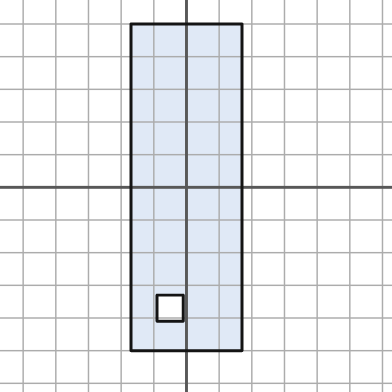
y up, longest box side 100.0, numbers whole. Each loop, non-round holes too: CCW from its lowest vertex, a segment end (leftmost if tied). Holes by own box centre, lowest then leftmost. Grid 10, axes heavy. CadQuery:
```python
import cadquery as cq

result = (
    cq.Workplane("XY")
    .moveTo(-17.0, -50.0)
    .lineTo(17.0, -50.0)
    .lineTo(17.0, 50.0)
    .lineTo(-17.0, 50.0)
    .close()
    .moveTo(-9.0, -41.0)
    .lineTo(-1.0, -41.0)
    .lineTo(-1.0, -33.0)
    .lineTo(-9.0, -33.0)
    .close()
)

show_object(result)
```